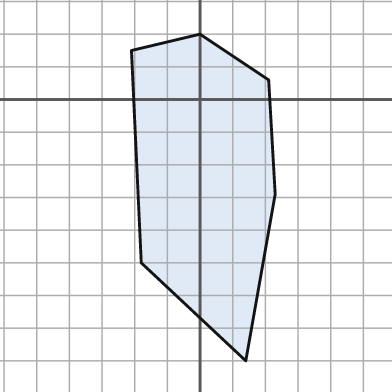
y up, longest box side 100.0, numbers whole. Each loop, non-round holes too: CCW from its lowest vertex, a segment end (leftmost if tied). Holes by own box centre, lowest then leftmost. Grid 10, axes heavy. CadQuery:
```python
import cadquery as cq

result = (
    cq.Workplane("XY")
    .moveTo(14.0, -80.0)
    .lineTo(23.0, -29.0)
    .lineTo(21.0, 6.0)
    .lineTo(0.0, 20.0)
    .lineTo(-21.0, 15.0)
    .lineTo(-18.0, -50.0)
    .close()
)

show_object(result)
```